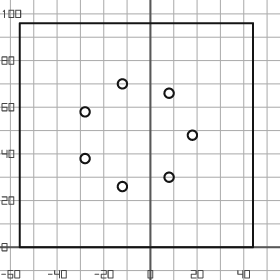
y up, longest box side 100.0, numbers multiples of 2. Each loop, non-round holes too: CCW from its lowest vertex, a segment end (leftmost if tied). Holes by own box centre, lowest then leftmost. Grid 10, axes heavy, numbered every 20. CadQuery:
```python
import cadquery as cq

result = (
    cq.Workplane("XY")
    .moveTo(-56.0, 0.0)
    .lineTo(44.0, 0.0)
    .lineTo(44.0, 96.0)
    .lineTo(-56.0, 96.0)
    .close()
    .moveTo(-12.0, 26.0)
    .circle(2.0)
    .moveTo(8.0, 30.0)
    .circle(2.0)
    .moveTo(-28.0, 38.0)
    .circle(2.0)
    .moveTo(18.0, 48.0)
    .circle(2.0)
    .moveTo(-28.0, 58.0)
    .circle(2.0)
    .moveTo(8.0, 66.0)
    .circle(2.0)
    .moveTo(-12.0, 70.0)
    .circle(2.0)
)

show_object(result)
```